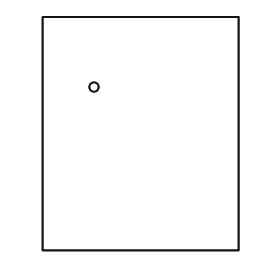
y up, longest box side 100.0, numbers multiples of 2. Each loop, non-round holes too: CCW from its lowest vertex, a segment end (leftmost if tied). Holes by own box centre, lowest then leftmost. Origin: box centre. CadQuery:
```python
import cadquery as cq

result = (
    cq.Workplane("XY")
    .moveTo(-42.0, -50.0)
    .lineTo(42.0, -50.0)
    .lineTo(42.0, 50.0)
    .lineTo(-42.0, 50.0)
    .close()
    .moveTo(-20.0, 20.0)
    .circle(2.0)
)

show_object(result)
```